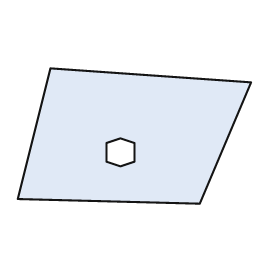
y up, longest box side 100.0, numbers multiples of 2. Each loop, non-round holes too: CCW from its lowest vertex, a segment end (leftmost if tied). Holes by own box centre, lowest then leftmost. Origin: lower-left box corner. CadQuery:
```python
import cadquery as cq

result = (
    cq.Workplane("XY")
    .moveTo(78.0, 0.0)
    .lineTo(100.0, 52.0)
    .lineTo(14.0, 58.0)
    .lineTo(0.0, 2.0)
    .close()
    .moveTo(44.0, 16.0)
    .lineTo(50.0, 18.0)
    .lineTo(50.0, 26.0)
    .lineTo(44.0, 28.0)
    .lineTo(38.0, 26.0)
    .lineTo(38.0, 18.0)
    .close()
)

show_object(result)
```